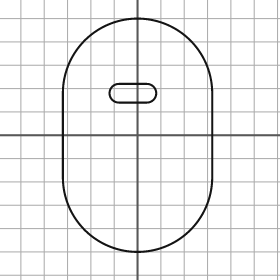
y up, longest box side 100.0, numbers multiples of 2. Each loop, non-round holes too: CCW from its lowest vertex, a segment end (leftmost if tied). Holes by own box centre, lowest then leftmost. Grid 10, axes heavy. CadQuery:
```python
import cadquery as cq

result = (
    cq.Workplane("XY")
    .moveTo(-32.0, -18.0)
    .threePointArc((0.0, -50.0), (32.0, -18.0))
    .lineTo(32.0, 18.0)
    .threePointArc((0.0, 50.0), (-32.0, 18.0))
    .close()
    .moveTo(-8.0, 14.0)
    .lineTo(4.0, 14.0)
    .threePointArc((8.0, 18.0), (4.0, 22.0))
    .lineTo(-8.0, 22.0)
    .threePointArc((-12.0, 18.0), (-8.0, 14.0))
    .close()
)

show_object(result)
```